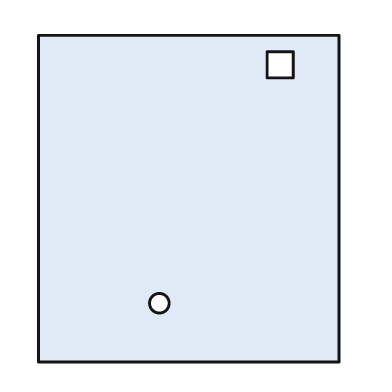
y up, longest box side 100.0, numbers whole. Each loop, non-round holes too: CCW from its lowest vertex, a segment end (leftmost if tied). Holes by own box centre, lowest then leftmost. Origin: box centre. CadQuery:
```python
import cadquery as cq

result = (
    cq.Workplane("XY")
    .moveTo(-46.0, -50.0)
    .lineTo(46.0, -50.0)
    .lineTo(46.0, 50.0)
    .lineTo(-46.0, 50.0)
    .close()
    .moveTo(-9.0, -32.0)
    .circle(3.0)
    .moveTo(24.0, 37.0)
    .lineTo(32.0, 37.0)
    .lineTo(32.0, 45.0)
    .lineTo(24.0, 45.0)
    .close()
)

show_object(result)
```